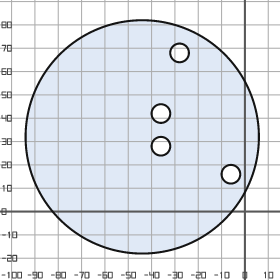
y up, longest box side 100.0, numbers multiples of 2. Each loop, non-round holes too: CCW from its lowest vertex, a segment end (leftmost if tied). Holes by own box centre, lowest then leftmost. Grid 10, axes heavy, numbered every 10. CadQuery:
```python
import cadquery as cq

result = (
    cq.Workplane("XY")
    .moveTo(-44.0, 32.0)
    .circle(50.0)
    .moveTo(-6.0, 16.0)
    .circle(4.0)
    .moveTo(-36.0, 28.0)
    .circle(4.0)
    .moveTo(-36.0, 42.0)
    .circle(4.0)
    .moveTo(-28.0, 68.0)
    .circle(4.0)
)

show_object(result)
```